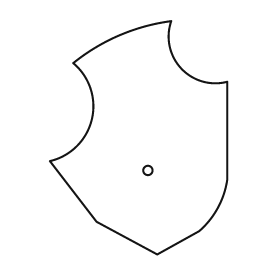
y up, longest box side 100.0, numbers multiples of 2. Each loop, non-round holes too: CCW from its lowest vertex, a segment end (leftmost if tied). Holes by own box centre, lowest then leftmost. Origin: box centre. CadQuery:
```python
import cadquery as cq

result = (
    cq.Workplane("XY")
    .moveTo(8.0, -50.0)
    .lineTo(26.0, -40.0)
    .threePointArc((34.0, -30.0), (38.0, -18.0))
    .lineTo(38.0, 24.0)
    .threePointArc((18.0, 30.0), (14.0, 50.0))
    .threePointArc((-8.0, 44.0), (-28.0, 32.0))
    .threePointArc((-20.0, 8.0), (-38.0, -10.0))
    .lineTo(-18.0, -36.0)
    .close()
    .moveTo(4.0, -14.0)
    .circle(2.0)
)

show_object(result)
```